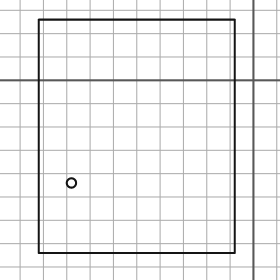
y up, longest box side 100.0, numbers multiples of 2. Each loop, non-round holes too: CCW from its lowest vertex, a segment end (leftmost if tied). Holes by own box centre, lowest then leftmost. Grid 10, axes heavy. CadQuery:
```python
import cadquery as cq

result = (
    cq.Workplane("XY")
    .moveTo(-92.0, -74.0)
    .lineTo(-8.0, -74.0)
    .lineTo(-8.0, 26.0)
    .lineTo(-92.0, 26.0)
    .close()
    .moveTo(-78.0, -44.0)
    .circle(2.0)
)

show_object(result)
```